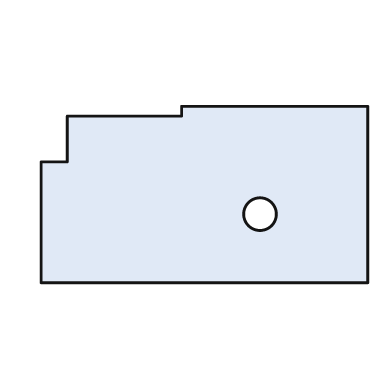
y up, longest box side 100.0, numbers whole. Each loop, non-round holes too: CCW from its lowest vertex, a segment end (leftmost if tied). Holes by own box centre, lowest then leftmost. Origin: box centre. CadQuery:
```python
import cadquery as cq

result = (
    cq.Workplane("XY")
    .moveTo(-50.0, -27.0)
    .lineTo(50.0, -27.0)
    .lineTo(50.0, 27.0)
    .lineTo(-7.0, 27.0)
    .lineTo(-7.0, 24.0)
    .lineTo(-42.0, 24.0)
    .lineTo(-42.0, 10.0)
    .lineTo(-50.0, 10.0)
    .close()
    .moveTo(17.0, -6.0)
    .circle(5.0)
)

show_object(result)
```